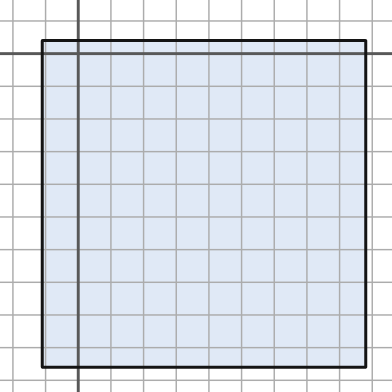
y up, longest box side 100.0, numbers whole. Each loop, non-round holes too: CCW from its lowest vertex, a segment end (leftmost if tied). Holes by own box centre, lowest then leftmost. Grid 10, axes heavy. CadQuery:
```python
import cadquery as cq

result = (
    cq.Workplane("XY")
    .moveTo(-11.0, -96.0)
    .lineTo(88.0, -96.0)
    .lineTo(88.0, 4.0)
    .lineTo(-11.0, 4.0)
    .close()
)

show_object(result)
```